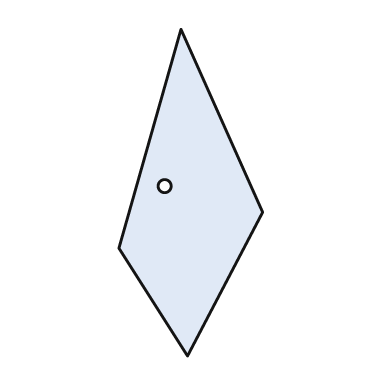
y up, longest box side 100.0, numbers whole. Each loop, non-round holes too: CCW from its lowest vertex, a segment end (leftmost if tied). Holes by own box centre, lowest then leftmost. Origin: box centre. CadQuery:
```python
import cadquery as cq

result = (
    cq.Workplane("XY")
    .moveTo(-1.0, -50.0)
    .lineTo(22.0, -6.0)
    .lineTo(-3.0, 50.0)
    .lineTo(-22.0, -17.0)
    .close()
    .moveTo(-8.0, 2.0)
    .circle(2.0)
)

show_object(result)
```